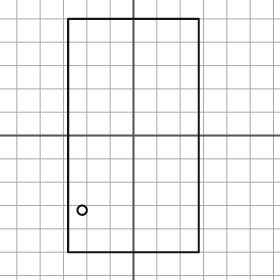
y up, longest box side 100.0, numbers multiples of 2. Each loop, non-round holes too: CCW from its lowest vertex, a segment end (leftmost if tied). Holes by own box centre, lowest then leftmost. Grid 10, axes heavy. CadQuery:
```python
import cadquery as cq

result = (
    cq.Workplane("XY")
    .moveTo(-28.0, -50.0)
    .lineTo(28.0, -50.0)
    .lineTo(28.0, 50.0)
    .lineTo(-28.0, 50.0)
    .close()
    .moveTo(-22.0, -32.0)
    .circle(2.0)
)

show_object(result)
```